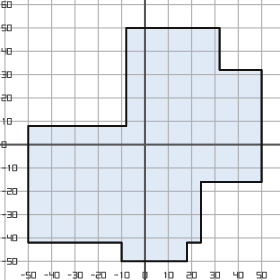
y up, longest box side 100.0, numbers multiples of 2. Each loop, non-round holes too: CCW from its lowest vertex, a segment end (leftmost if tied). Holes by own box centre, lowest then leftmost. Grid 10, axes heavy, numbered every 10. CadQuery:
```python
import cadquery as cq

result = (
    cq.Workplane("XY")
    .moveTo(-10.0, -50.0)
    .lineTo(18.0, -50.0)
    .lineTo(18.0, -42.0)
    .lineTo(24.0, -42.0)
    .lineTo(24.0, -16.0)
    .lineTo(50.0, -16.0)
    .lineTo(50.0, 32.0)
    .lineTo(32.0, 32.0)
    .lineTo(32.0, 50.0)
    .lineTo(-8.0, 50.0)
    .lineTo(-8.0, 8.0)
    .lineTo(-50.0, 8.0)
    .lineTo(-50.0, -42.0)
    .lineTo(-10.0, -42.0)
    .close()
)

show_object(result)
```